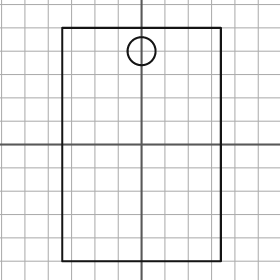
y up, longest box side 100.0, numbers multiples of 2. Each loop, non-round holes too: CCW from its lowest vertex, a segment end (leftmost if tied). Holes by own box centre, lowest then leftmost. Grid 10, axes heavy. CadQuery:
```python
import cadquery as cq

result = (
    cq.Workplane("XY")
    .moveTo(-34.0, -50.0)
    .lineTo(34.0, -50.0)
    .lineTo(34.0, 50.0)
    .lineTo(-34.0, 50.0)
    .close()
    .moveTo(0.0, 40.0)
    .circle(6.0)
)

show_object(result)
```